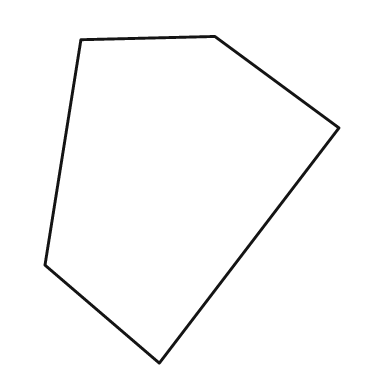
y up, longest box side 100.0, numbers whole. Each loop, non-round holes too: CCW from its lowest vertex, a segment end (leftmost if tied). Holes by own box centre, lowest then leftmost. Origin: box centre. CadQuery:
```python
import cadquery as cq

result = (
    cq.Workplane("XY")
    .moveTo(-10.0, -50.0)
    .lineTo(45.0, 22.0)
    .lineTo(7.0, 50.0)
    .lineTo(-34.0, 49.0)
    .lineTo(-45.0, -20.0)
    .close()
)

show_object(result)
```